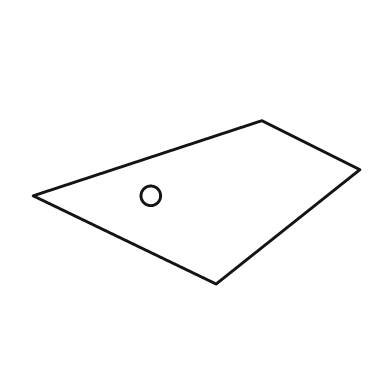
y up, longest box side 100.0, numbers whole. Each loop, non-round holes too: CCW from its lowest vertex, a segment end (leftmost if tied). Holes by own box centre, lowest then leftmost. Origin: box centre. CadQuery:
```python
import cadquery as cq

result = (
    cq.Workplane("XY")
    .moveTo(6.0, -25.0)
    .lineTo(50.0, 10.0)
    .lineTo(20.0, 25.0)
    .lineTo(-50.0, 2.0)
    .close()
    .moveTo(-14.0, 2.0)
    .circle(3.0)
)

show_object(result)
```